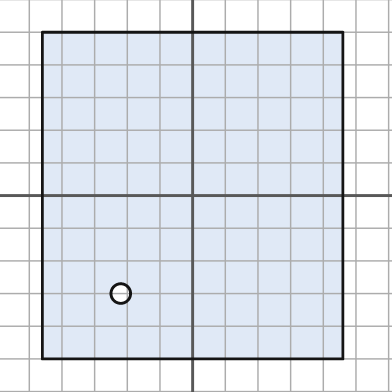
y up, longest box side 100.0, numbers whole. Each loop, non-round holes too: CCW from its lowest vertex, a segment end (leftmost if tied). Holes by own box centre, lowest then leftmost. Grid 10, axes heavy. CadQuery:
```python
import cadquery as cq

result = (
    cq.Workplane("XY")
    .moveTo(-46.0, -50.0)
    .lineTo(46.0, -50.0)
    .lineTo(46.0, 50.0)
    .lineTo(-46.0, 50.0)
    .close()
    .moveTo(-22.0, -30.0)
    .circle(3.0)
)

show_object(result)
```